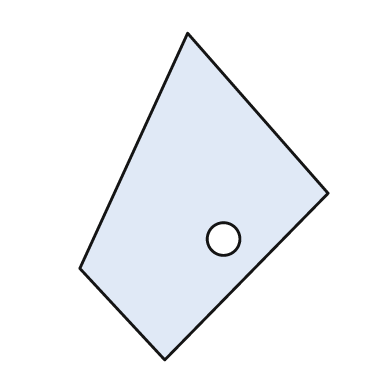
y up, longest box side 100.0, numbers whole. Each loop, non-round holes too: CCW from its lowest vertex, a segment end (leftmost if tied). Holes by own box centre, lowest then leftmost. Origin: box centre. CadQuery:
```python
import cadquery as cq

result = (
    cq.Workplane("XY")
    .moveTo(-12.0, -50.0)
    .lineTo(38.0, 1.0)
    .lineTo(-5.0, 50.0)
    .lineTo(-38.0, -22.0)
    .close()
    .moveTo(6.0, -13.0)
    .circle(5.0)
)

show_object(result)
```